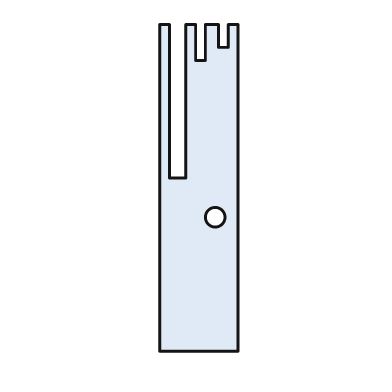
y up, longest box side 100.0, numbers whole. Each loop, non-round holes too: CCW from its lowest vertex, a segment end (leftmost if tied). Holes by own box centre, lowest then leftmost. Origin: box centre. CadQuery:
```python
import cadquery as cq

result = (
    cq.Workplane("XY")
    .moveTo(-12.0, -50.0)
    .lineTo(12.0, -50.0)
    .lineTo(12.0, 50.0)
    .lineTo(9.0, 50.0)
    .lineTo(9.0, 43.0)
    .lineTo(6.0, 43.0)
    .lineTo(6.0, 50.0)
    .lineTo(2.0, 50.0)
    .lineTo(2.0, 39.0)
    .lineTo(-1.0, 39.0)
    .lineTo(-1.0, 50.0)
    .lineTo(-4.0, 50.0)
    .lineTo(-4.0, 3.0)
    .lineTo(-9.0, 3.0)
    .lineTo(-9.0, 50.0)
    .lineTo(-12.0, 50.0)
    .close()
    .moveTo(5.0, -9.0)
    .circle(3.0)
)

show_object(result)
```